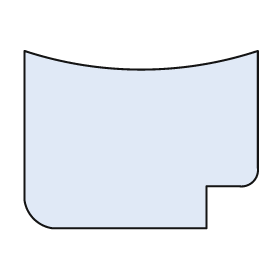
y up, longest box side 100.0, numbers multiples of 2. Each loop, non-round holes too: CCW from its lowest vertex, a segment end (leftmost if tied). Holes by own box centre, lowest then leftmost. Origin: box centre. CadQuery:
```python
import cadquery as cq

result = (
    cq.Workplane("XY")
    .moveTo(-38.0, -38.0)
    .lineTo(28.0, -38.0)
    .lineTo(28.0, -20.0)
    .lineTo(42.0, -20.0)
    .threePointArc((48.0, -18.0), (50.0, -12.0))
    .lineTo(50.0, 38.0)
    .threePointArc((0.0, 30.0), (-50.0, 38.0))
    .lineTo(-50.0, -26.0)
    .threePointArc((-46.0, -34.0), (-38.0, -38.0))
    .close()
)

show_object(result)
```